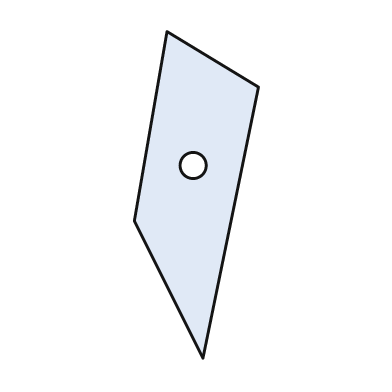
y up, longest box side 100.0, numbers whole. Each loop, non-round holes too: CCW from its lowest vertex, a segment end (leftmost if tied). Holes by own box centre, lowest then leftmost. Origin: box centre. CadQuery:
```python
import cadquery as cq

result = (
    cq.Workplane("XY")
    .moveTo(2.0, -50.0)
    .lineTo(19.0, 33.0)
    .lineTo(-9.0, 50.0)
    .lineTo(-19.0, -8.0)
    .close()
    .moveTo(-1.0, 9.0)
    .circle(4.0)
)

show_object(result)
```